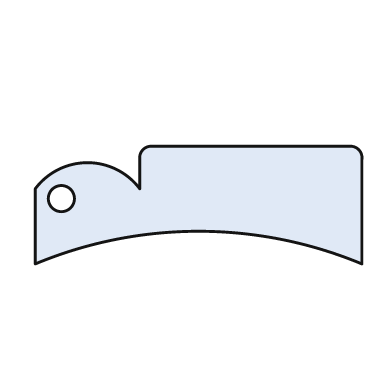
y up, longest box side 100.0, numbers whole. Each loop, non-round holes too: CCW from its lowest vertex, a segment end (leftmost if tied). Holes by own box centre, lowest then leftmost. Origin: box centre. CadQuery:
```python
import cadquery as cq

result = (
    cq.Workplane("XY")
    .moveTo(-50.0, -18.0)
    .threePointArc((0.0, -8.0), (50.0, -18.0))
    .lineTo(50.0, 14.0)
    .threePointArc((49.0, 17.0), (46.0, 18.0))
    .lineTo(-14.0, 18.0)
    .threePointArc((-17.0, 17.0), (-18.0, 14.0))
    .lineTo(-18.0, 5.0)
    .threePointArc((-34.0, 13.0), (-50.0, 5.0))
    .close()
    .moveTo(-42.0, 2.0)
    .circle(4.0)
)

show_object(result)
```